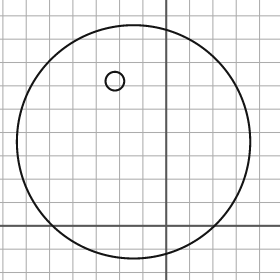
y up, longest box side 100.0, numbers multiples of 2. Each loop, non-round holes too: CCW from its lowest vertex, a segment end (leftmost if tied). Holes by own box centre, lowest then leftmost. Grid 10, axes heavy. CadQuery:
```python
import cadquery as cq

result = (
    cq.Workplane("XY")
    .moveTo(-14.0, 36.0)
    .circle(50.0)
    .moveTo(-22.0, 62.0)
    .circle(4.0)
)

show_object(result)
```